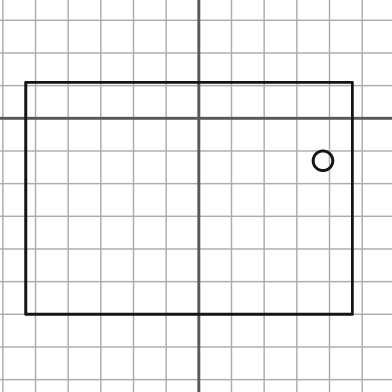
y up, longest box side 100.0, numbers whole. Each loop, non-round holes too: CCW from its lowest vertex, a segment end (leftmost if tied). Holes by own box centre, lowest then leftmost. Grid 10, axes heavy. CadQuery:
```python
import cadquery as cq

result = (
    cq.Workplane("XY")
    .moveTo(-53.0, -60.0)
    .lineTo(47.0, -60.0)
    .lineTo(47.0, 11.0)
    .lineTo(-53.0, 11.0)
    .close()
    .moveTo(38.0, -13.0)
    .circle(3.0)
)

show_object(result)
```